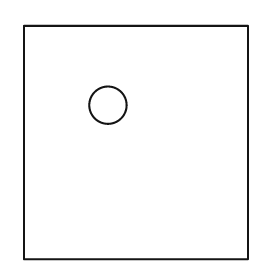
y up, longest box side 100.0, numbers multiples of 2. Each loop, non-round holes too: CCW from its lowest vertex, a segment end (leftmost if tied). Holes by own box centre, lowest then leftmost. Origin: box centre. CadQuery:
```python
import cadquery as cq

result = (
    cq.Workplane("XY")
    .moveTo(-48.0, -50.0)
    .lineTo(48.0, -50.0)
    .lineTo(48.0, 50.0)
    .lineTo(-48.0, 50.0)
    .close()
    .moveTo(-12.0, 16.0)
    .circle(8.0)
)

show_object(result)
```